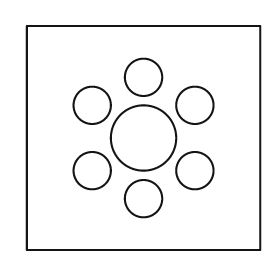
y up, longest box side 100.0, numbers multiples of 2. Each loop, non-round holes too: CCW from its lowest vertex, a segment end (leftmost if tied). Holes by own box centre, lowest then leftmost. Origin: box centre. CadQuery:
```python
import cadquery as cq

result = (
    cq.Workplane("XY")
    .moveTo(-50.0, -48.0)
    .lineTo(50.0, -48.0)
    .lineTo(50.0, 48.0)
    .lineTo(-50.0, 48.0)
    .close()
    .moveTo(0.0, -26.0)
    .circle(8.0)
    .moveTo(-22.0, -14.0)
    .circle(8.0)
    .moveTo(22.0, -14.0)
    .circle(8.0)
    .moveTo(0.0, 0.0)
    .circle(14.0)
    .moveTo(-22.0, 14.0)
    .circle(8.0)
    .moveTo(22.0, 14.0)
    .circle(8.0)
    .moveTo(0.0, 26.0)
    .circle(8.0)
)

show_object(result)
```